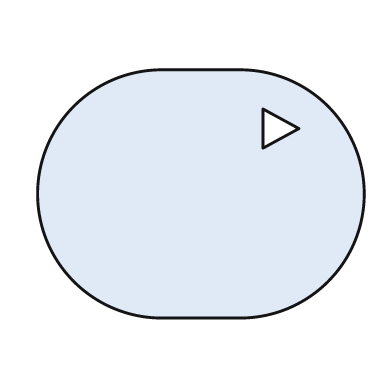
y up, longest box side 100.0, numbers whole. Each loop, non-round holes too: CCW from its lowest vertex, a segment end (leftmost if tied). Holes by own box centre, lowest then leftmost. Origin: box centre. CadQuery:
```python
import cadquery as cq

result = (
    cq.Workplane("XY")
    .moveTo(-12.0, -38.0)
    .lineTo(12.0, -38.0)
    .threePointArc((50.0, 0.0), (12.0, 38.0))
    .lineTo(-12.0, 38.0)
    .threePointArc((-50.0, 0.0), (-12.0, -38.0))
    .close()
    .moveTo(19.0, 14.0)
    .lineTo(30.0, 20.0)
    .lineTo(19.0, 26.0)
    .close()
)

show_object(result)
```